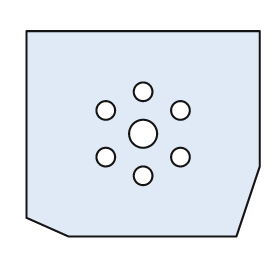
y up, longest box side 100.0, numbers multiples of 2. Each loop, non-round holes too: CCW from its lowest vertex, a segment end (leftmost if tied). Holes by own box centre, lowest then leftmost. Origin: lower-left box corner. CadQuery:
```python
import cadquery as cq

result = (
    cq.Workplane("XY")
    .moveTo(18.0, 0.0)
    .lineTo(90.0, 0.0)
    .lineTo(100.0, 30.0)
    .lineTo(100.0, 88.0)
    .lineTo(0.0, 88.0)
    .lineTo(0.0, 8.0)
    .close()
    .moveTo(50.0, 26.0)
    .circle(4.0)
    .moveTo(34.0, 34.0)
    .circle(4.0)
    .moveTo(66.0, 34.0)
    .circle(4.0)
    .moveTo(50.0, 44.0)
    .circle(6.0)
    .moveTo(34.0, 54.0)
    .circle(4.0)
    .moveTo(66.0, 54.0)
    .circle(4.0)
    .moveTo(50.0, 62.0)
    .circle(4.0)
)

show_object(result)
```